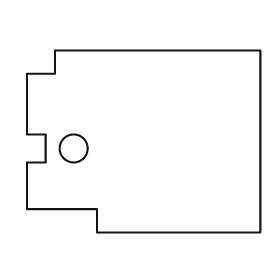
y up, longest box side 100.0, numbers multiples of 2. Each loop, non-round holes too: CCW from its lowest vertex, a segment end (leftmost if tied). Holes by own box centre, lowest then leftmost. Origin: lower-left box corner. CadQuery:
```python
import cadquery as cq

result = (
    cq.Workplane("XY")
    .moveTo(30.0, 0.0)
    .lineTo(100.0, 0.0)
    .lineTo(100.0, 78.0)
    .lineTo(12.0, 78.0)
    .lineTo(12.0, 68.0)
    .lineTo(0.0, 68.0)
    .lineTo(0.0, 42.0)
    .lineTo(8.0, 42.0)
    .lineTo(8.0, 30.0)
    .lineTo(0.0, 30.0)
    .lineTo(0.0, 10.0)
    .lineTo(30.0, 10.0)
    .close()
    .moveTo(20.0, 36.0)
    .circle(6.0)
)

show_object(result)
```